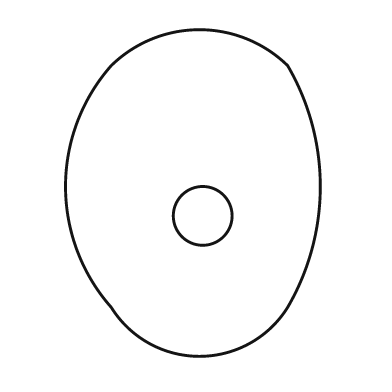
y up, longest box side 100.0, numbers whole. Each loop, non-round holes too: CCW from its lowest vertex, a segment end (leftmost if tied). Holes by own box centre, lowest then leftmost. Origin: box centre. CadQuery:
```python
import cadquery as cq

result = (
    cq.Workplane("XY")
    .moveTo(-25.0, -35.0)
    .threePointArc((2.0, -50.0), (29.0, -35.0))
    .threePointArc((39.0, 2.0), (29.0, 39.0))
    .threePointArc((2.0, 50.0), (-25.0, 39.0))
    .threePointArc((-39.0, 2.0), (-25.0, -35.0))
    .close()
    .moveTo(3.0, -7.0)
    .circle(9.0)
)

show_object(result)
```